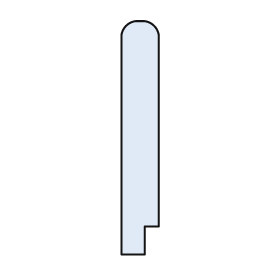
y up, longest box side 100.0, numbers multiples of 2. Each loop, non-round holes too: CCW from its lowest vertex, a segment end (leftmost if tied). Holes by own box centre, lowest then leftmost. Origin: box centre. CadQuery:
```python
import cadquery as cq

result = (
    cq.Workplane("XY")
    .moveTo(-8.0, -50.0)
    .lineTo(2.0, -50.0)
    .lineTo(2.0, -38.0)
    .lineTo(8.0, -38.0)
    .lineTo(8.0, 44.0)
    .threePointArc((6.0, 48.0), (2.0, 50.0))
    .lineTo(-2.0, 50.0)
    .threePointArc((-6.0, 48.0), (-8.0, 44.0))
    .close()
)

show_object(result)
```